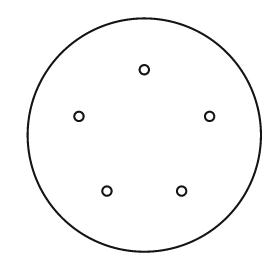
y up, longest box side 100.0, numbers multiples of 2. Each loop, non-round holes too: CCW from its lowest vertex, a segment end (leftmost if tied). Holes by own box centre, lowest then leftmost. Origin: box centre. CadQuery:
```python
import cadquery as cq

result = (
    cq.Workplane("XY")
    .moveTo(0.0, 0.0)
    .circle(50.0)
    .moveTo(-16.0, -24.0)
    .circle(2.0)
    .moveTo(16.0, -24.0)
    .circle(2.0)
    .moveTo(-28.0, 8.0)
    .circle(2.0)
    .moveTo(28.0, 8.0)
    .circle(2.0)
    .moveTo(0.0, 28.0)
    .circle(2.0)
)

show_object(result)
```